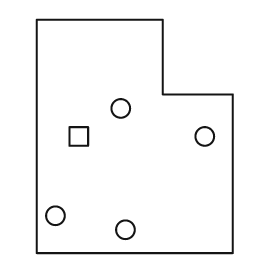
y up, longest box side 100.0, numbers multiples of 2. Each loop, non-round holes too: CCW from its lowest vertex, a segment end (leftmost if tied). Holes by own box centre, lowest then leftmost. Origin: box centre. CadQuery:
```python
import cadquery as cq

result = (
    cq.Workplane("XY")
    .moveTo(-42.0, -50.0)
    .lineTo(42.0, -50.0)
    .lineTo(42.0, 18.0)
    .lineTo(12.0, 18.0)
    .lineTo(12.0, 50.0)
    .lineTo(-42.0, 50.0)
    .close()
    .moveTo(-4.0, -40.0)
    .circle(4.0)
    .moveTo(-34.0, -34.0)
    .circle(4.0)
    .moveTo(-28.0, -4.0)
    .lineTo(-20.0, -4.0)
    .lineTo(-20.0, 4.0)
    .lineTo(-28.0, 4.0)
    .close()
    .moveTo(30.0, 0.0)
    .circle(4.0)
    .moveTo(-6.0, 12.0)
    .circle(4.0)
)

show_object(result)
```